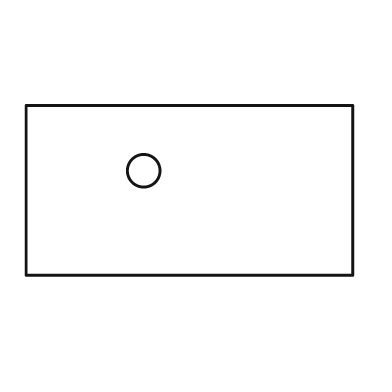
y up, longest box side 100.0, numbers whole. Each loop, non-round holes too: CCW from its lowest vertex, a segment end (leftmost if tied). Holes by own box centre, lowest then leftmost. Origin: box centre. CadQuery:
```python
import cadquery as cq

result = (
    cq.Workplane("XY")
    .moveTo(-50.0, -26.0)
    .lineTo(50.0, -26.0)
    .lineTo(50.0, 26.0)
    .lineTo(-50.0, 26.0)
    .close()
    .moveTo(-14.0, 6.0)
    .circle(5.0)
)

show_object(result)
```